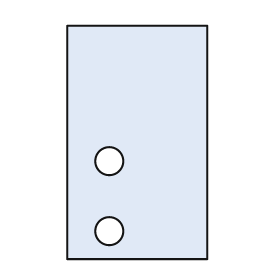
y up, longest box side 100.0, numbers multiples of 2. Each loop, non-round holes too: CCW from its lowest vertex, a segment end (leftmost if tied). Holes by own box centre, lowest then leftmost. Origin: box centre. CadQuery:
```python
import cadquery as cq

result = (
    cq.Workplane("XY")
    .moveTo(-30.0, -50.0)
    .lineTo(30.0, -50.0)
    .lineTo(30.0, 50.0)
    .lineTo(-30.0, 50.0)
    .close()
    .moveTo(-12.0, -38.0)
    .circle(6.0)
    .moveTo(-12.0, -8.0)
    .circle(6.0)
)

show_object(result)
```